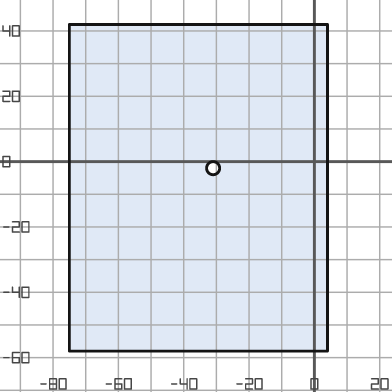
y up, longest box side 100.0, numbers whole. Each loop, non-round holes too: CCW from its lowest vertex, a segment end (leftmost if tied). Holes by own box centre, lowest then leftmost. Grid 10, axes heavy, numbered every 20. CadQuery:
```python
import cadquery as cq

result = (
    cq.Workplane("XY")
    .moveTo(-75.0, -58.0)
    .lineTo(4.0, -58.0)
    .lineTo(4.0, 42.0)
    .lineTo(-75.0, 42.0)
    .close()
    .moveTo(-31.0, -2.0)
    .circle(2.0)
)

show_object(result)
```